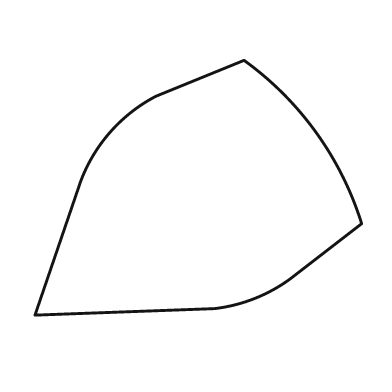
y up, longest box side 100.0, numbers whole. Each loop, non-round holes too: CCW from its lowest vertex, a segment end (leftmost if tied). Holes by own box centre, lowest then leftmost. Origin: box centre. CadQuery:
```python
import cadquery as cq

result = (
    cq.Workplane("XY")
    .moveTo(-50.0, -39.0)
    .lineTo(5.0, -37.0)
    .threePointArc((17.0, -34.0), (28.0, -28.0))
    .lineTo(50.0, -11.0)
    .threePointArc((36.0, 17.0), (14.0, 39.0))
    .lineTo(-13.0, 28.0)
    .threePointArc((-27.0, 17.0), (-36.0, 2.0))
    .close()
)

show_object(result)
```